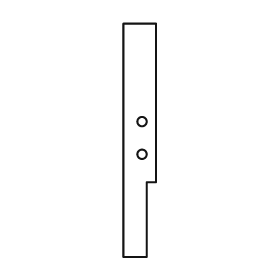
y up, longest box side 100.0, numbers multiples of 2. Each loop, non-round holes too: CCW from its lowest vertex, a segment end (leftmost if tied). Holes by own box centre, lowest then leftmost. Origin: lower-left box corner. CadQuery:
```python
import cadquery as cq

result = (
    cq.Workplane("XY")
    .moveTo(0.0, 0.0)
    .lineTo(10.0, 0.0)
    .lineTo(10.0, 32.0)
    .lineTo(14.0, 32.0)
    .lineTo(14.0, 100.0)
    .lineTo(0.0, 100.0)
    .close()
    .moveTo(8.0, 44.0)
    .circle(2.0)
    .moveTo(8.0, 58.0)
    .circle(2.0)
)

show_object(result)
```